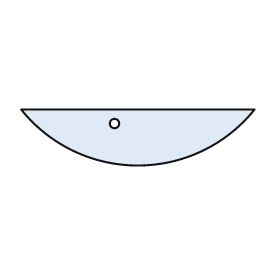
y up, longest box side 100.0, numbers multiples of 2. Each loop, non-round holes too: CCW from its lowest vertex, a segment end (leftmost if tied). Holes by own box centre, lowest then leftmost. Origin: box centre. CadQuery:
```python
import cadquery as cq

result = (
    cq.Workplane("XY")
    .moveTo(-50.0, 12.0)
    .threePointArc((0.0, -12.0), (50.0, 12.0))
    .close()
    .moveTo(-10.0, 6.0)
    .circle(2.0)
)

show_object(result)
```